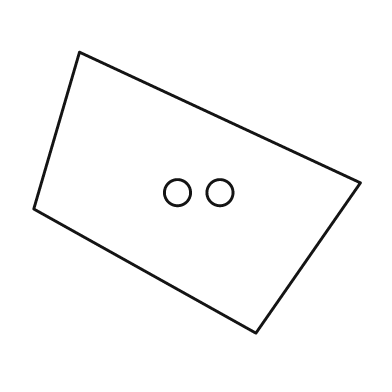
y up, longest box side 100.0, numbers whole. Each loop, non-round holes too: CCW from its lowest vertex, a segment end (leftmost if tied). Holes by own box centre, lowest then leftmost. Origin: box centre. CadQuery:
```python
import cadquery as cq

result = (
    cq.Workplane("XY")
    .moveTo(18.0, -43.0)
    .lineTo(50.0, 3.0)
    .lineTo(-36.0, 43.0)
    .lineTo(-50.0, -5.0)
    .close()
    .moveTo(-6.0, 0.0)
    .circle(4.0)
    .moveTo(7.0, 0.0)
    .circle(4.0)
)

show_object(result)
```